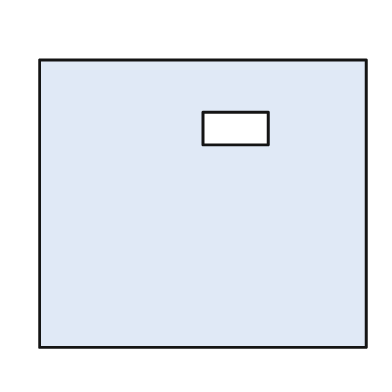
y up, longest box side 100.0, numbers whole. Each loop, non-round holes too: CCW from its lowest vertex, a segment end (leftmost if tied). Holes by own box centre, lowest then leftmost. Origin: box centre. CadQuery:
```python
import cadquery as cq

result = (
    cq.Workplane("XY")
    .moveTo(-50.0, -44.0)
    .lineTo(50.0, -44.0)
    .lineTo(50.0, 44.0)
    .lineTo(-50.0, 44.0)
    .close()
    .moveTo(0.0, 18.0)
    .lineTo(20.0, 18.0)
    .lineTo(20.0, 28.0)
    .lineTo(0.0, 28.0)
    .close()
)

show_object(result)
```